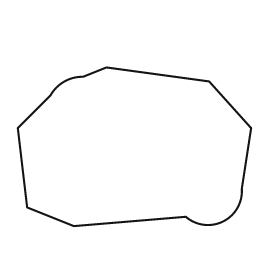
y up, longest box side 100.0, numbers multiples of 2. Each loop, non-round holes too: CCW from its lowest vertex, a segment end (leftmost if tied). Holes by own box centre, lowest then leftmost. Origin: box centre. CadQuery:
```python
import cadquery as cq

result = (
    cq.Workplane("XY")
    .moveTo(-26.0, -34.0)
    .lineTo(22.0, -30.0)
    .threePointArc((38.0, -32.0), (46.0, -18.0))
    .lineTo(50.0, 8.0)
    .lineTo(32.0, 28.0)
    .lineTo(-12.0, 34.0)
    .lineTo(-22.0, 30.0)
    .threePointArc((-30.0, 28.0), (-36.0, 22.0))
    .lineTo(-50.0, 8.0)
    .lineTo(-46.0, -26.0)
    .close()
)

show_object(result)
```